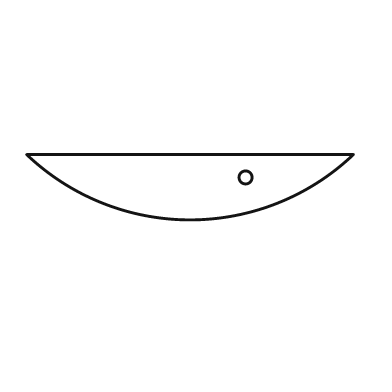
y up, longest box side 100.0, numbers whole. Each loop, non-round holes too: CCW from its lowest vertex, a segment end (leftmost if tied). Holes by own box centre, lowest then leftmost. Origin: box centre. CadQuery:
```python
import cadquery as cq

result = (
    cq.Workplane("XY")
    .moveTo(-50.0, 10.0)
    .threePointArc((0.0, -10.0), (50.0, 10.0))
    .close()
    .moveTo(17.0, 3.0)
    .circle(2.0)
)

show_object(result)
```